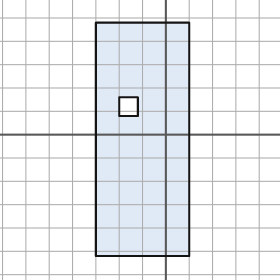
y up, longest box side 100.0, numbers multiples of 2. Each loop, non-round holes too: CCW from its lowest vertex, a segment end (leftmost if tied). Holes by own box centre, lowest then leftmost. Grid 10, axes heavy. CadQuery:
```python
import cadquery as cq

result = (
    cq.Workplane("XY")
    .moveTo(-30.0, -52.0)
    .lineTo(10.0, -52.0)
    .lineTo(10.0, 48.0)
    .lineTo(-30.0, 48.0)
    .close()
    .moveTo(-20.0, 8.0)
    .lineTo(-12.0, 8.0)
    .lineTo(-12.0, 16.0)
    .lineTo(-20.0, 16.0)
    .close()
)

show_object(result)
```